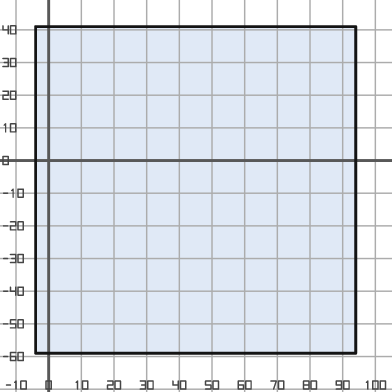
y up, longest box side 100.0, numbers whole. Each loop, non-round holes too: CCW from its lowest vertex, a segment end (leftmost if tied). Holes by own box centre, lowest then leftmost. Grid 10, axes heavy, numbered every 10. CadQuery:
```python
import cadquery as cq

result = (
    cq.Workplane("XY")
    .moveTo(-4.0, -59.0)
    .lineTo(94.0, -59.0)
    .lineTo(94.0, 41.0)
    .lineTo(-4.0, 41.0)
    .close()
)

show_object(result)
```